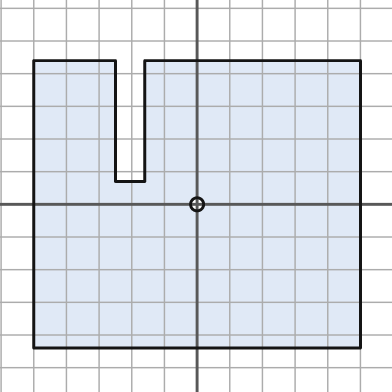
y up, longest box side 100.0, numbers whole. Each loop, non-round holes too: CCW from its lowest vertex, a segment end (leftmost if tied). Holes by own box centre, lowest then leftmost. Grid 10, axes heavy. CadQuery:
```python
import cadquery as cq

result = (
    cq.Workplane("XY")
    .moveTo(-50.0, -44.0)
    .lineTo(50.0, -44.0)
    .lineTo(50.0, 44.0)
    .lineTo(-16.0, 44.0)
    .lineTo(-16.0, 7.0)
    .lineTo(-25.0, 7.0)
    .lineTo(-25.0, 44.0)
    .lineTo(-50.0, 44.0)
    .close()
    .moveTo(0.0, 0.0)
    .circle(2.0)
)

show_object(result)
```